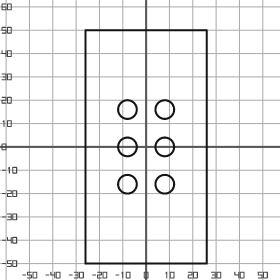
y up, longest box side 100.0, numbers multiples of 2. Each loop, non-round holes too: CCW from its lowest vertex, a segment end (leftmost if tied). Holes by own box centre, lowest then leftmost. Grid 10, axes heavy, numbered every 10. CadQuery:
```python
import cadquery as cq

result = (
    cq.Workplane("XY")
    .moveTo(-26.0, -50.0)
    .lineTo(26.0, -50.0)
    .lineTo(26.0, 50.0)
    .lineTo(-26.0, 50.0)
    .close()
    .moveTo(-8.0, -16.0)
    .circle(4.0)
    .moveTo(8.0, -16.0)
    .circle(4.0)
    .moveTo(-8.0, 0.0)
    .circle(4.0)
    .moveTo(8.0, 0.0)
    .circle(4.0)
    .moveTo(-8.0, 16.0)
    .circle(4.0)
    .moveTo(8.0, 16.0)
    .circle(4.0)
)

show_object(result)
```